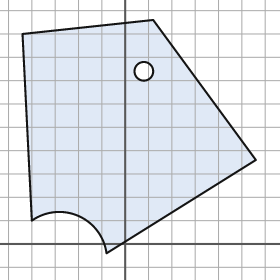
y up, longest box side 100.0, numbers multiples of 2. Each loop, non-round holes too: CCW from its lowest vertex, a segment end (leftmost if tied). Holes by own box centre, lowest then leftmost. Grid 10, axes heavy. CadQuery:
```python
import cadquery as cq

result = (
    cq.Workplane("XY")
    .moveTo(-8.0, -4.0)
    .lineTo(56.0, 36.0)
    .lineTo(12.0, 96.0)
    .lineTo(-44.0, 90.0)
    .lineTo(-40.0, 10.0)
    .threePointArc((-20.0, 12.0), (-8.0, -4.0))
    .close()
    .moveTo(8.0, 74.0)
    .circle(4.0)
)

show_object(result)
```